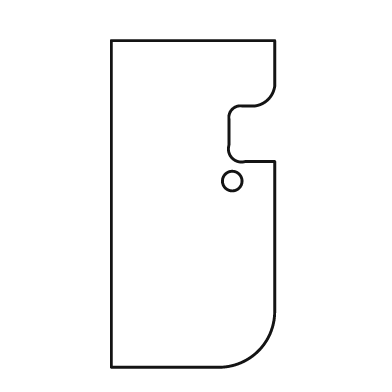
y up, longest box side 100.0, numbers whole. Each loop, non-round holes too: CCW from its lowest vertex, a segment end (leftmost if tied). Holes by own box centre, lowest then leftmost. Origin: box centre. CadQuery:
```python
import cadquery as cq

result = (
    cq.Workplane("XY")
    .moveTo(-25.0, -50.0)
    .lineTo(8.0, -50.0)
    .threePointArc((20.0, -45.0), (25.0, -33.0))
    .lineTo(25.0, 13.0)
    .lineTo(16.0, 13.0)
    .threePointArc((12.0, 14.0), (11.0, 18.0))
    .lineTo(11.0, 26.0)
    .threePointArc((12.0, 29.0), (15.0, 30.0))
    .lineTo(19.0, 30.0)
    .threePointArc((23.0, 32.0), (25.0, 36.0))
    .lineTo(25.0, 50.0)
    .lineTo(-25.0, 50.0)
    .close()
    .moveTo(12.0, 7.0)
    .circle(3.0)
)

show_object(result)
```